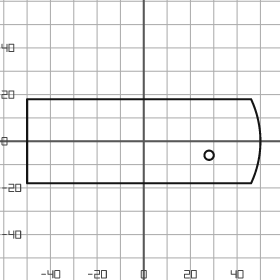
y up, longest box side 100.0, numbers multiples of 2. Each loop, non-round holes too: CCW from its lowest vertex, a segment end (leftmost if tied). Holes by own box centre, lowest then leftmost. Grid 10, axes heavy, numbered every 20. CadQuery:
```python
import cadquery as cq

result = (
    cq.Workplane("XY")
    .moveTo(-50.0, -18.0)
    .lineTo(46.0, -18.0)
    .threePointArc((50.0, 0.0), (46.0, 18.0))
    .lineTo(-50.0, 18.0)
    .close()
    .moveTo(28.0, -6.0)
    .circle(2.0)
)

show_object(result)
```